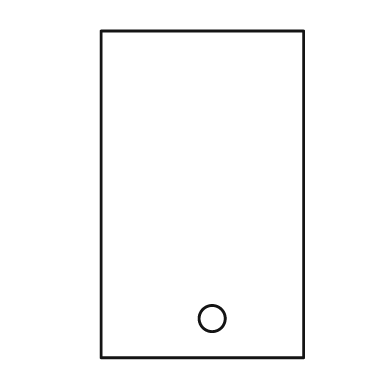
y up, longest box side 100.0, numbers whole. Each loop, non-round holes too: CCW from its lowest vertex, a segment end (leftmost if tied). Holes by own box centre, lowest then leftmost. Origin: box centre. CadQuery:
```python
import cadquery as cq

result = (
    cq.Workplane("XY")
    .moveTo(-31.0, -50.0)
    .lineTo(31.0, -50.0)
    .lineTo(31.0, 50.0)
    .lineTo(-31.0, 50.0)
    .close()
    .moveTo(3.0, -38.0)
    .circle(4.0)
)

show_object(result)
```